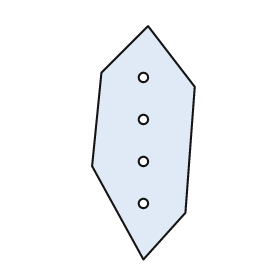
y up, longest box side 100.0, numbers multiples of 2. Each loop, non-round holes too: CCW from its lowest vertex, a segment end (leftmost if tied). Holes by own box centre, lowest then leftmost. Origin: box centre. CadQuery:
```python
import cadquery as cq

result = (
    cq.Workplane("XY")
    .moveTo(0.0, -50.0)
    .lineTo(18.0, -30.0)
    .lineTo(22.0, 24.0)
    .lineTo(2.0, 50.0)
    .lineTo(-18.0, 30.0)
    .lineTo(-22.0, -10.0)
    .close()
    .moveTo(0.0, -26.0)
    .circle(2.0)
    .moveTo(0.0, -8.0)
    .circle(2.0)
    .moveTo(0.0, 10.0)
    .circle(2.0)
    .moveTo(0.0, 28.0)
    .circle(2.0)
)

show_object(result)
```